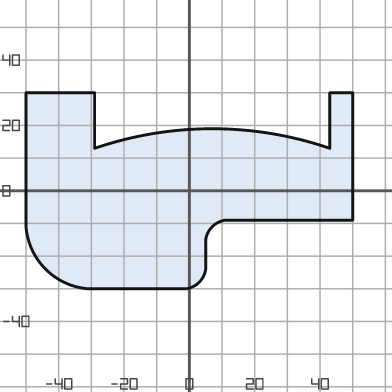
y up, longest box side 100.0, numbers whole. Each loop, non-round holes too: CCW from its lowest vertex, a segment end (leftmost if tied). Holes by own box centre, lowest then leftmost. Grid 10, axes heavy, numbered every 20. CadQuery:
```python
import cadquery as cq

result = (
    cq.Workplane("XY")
    .moveTo(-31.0, -30.0)
    .lineTo(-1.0, -30.0)
    .threePointArc((3.0, -28.0), (5.0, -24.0))
    .lineTo(5.0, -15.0)
    .threePointArc((7.0, -11.0), (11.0, -9.0))
    .lineTo(50.0, -9.0)
    .lineTo(50.0, 30.0)
    .lineTo(43.0, 30.0)
    .lineTo(43.0, 13.0)
    .threePointArc((7.0, 19.0), (-29.0, 13.0))
    .lineTo(-29.0, 30.0)
    .lineTo(-50.0, 30.0)
    .lineTo(-50.0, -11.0)
    .threePointArc((-44.0, -24.0), (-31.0, -30.0))
    .close()
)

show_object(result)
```